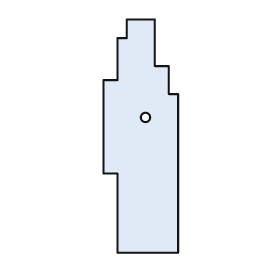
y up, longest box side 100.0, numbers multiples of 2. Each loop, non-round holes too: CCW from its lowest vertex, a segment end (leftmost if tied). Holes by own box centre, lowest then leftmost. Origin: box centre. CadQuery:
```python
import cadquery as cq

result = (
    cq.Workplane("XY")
    .moveTo(-10.0, -50.0)
    .lineTo(16.0, -50.0)
    .lineTo(16.0, 18.0)
    .lineTo(12.0, 18.0)
    .lineTo(12.0, 30.0)
    .lineTo(6.0, 30.0)
    .lineTo(6.0, 50.0)
    .lineTo(-6.0, 50.0)
    .lineTo(-6.0, 42.0)
    .lineTo(-10.0, 42.0)
    .lineTo(-10.0, 24.0)
    .lineTo(-16.0, 24.0)
    .lineTo(-16.0, -16.0)
    .lineTo(-10.0, -16.0)
    .close()
    .moveTo(2.0, 8.0)
    .circle(2.0)
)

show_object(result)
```